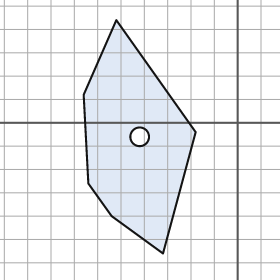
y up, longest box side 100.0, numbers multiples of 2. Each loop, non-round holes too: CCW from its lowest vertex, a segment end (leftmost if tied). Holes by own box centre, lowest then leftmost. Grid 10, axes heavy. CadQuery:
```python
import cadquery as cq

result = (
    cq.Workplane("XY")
    .moveTo(-32.0, -56.0)
    .lineTo(-18.0, -4.0)
    .lineTo(-52.0, 44.0)
    .lineTo(-66.0, 12.0)
    .lineTo(-64.0, -26.0)
    .lineTo(-54.0, -40.0)
    .close()
    .moveTo(-42.0, -6.0)
    .circle(4.0)
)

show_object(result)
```